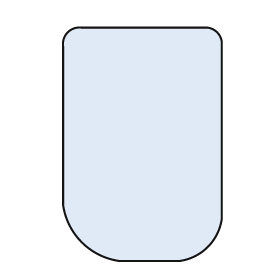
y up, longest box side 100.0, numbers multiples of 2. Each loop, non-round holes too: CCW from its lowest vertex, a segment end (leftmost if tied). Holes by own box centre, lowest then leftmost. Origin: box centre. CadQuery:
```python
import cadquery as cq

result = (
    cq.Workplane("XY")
    .moveTo(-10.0, -50.0)
    .lineTo(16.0, -50.0)
    .threePointArc((28.0, -44.0), (34.0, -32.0))
    .lineTo(34.0, 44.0)
    .threePointArc((32.0, 48.0), (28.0, 50.0))
    .lineTo(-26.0, 50.0)
    .threePointArc((-32.0, 48.0), (-34.0, 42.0))
    .lineTo(-34.0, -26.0)
    .threePointArc((-26.0, -42.0), (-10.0, -50.0))
    .close()
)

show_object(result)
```